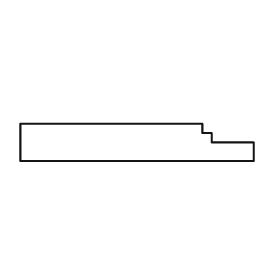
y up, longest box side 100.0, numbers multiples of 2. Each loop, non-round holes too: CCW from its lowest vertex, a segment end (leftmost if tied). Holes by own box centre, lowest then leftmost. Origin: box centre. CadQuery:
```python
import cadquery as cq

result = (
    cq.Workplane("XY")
    .moveTo(-50.0, -8.0)
    .lineTo(50.0, -8.0)
    .lineTo(50.0, 0.0)
    .lineTo(32.0, 0.0)
    .lineTo(32.0, 4.0)
    .lineTo(28.0, 4.0)
    .lineTo(28.0, 8.0)
    .lineTo(-50.0, 8.0)
    .close()
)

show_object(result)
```